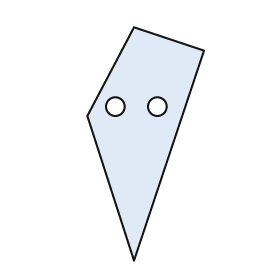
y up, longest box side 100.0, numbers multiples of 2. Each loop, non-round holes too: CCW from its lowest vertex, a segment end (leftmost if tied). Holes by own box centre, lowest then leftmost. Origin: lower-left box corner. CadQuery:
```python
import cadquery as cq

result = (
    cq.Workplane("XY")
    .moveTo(20.0, 0.0)
    .lineTo(50.0, 90.0)
    .lineTo(20.0, 100.0)
    .lineTo(0.0, 62.0)
    .close()
    .moveTo(12.0, 66.0)
    .circle(4.0)
    .moveTo(30.0, 66.0)
    .circle(4.0)
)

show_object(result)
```